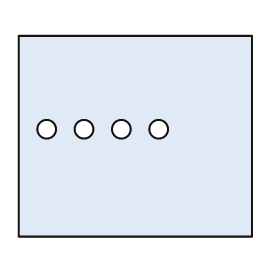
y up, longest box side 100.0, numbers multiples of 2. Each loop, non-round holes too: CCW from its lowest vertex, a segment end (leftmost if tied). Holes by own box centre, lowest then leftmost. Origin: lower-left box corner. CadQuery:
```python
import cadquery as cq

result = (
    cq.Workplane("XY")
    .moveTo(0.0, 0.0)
    .lineTo(100.0, 0.0)
    .lineTo(100.0, 86.0)
    .lineTo(0.0, 86.0)
    .close()
    .moveTo(12.0, 46.0)
    .circle(4.0)
    .moveTo(28.0, 46.0)
    .circle(4.0)
    .moveTo(44.0, 46.0)
    .circle(4.0)
    .moveTo(60.0, 46.0)
    .circle(4.0)
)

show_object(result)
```